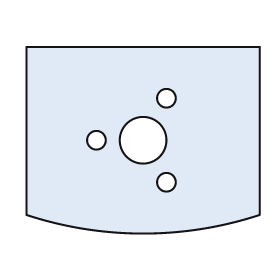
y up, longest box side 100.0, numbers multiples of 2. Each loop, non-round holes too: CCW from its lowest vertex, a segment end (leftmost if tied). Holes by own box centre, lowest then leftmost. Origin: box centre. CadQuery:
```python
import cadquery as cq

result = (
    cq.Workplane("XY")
    .moveTo(-50.0, -32.0)
    .threePointArc((0.0, -40.0), (50.0, -32.0))
    .lineTo(50.0, 40.0)
    .lineTo(-50.0, 40.0)
    .close()
    .moveTo(10.0, -18.0)
    .circle(4.0)
    .moveTo(-20.0, 0.0)
    .circle(4.0)
    .moveTo(0.0, 0.0)
    .circle(10.0)
    .moveTo(10.0, 18.0)
    .circle(4.0)
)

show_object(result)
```